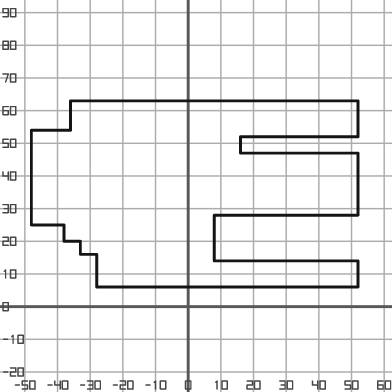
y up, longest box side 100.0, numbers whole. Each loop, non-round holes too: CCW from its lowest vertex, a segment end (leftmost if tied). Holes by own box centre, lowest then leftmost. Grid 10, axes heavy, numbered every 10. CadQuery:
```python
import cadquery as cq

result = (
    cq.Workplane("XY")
    .moveTo(-28.0, 6.0)
    .lineTo(52.0, 6.0)
    .lineTo(52.0, 14.0)
    .lineTo(8.0, 14.0)
    .lineTo(8.0, 28.0)
    .lineTo(52.0, 28.0)
    .lineTo(52.0, 47.0)
    .lineTo(16.0, 47.0)
    .lineTo(16.0, 52.0)
    .lineTo(52.0, 52.0)
    .lineTo(52.0, 63.0)
    .lineTo(-36.0, 63.0)
    .lineTo(-36.0, 54.0)
    .lineTo(-48.0, 54.0)
    .lineTo(-48.0, 25.0)
    .lineTo(-38.0, 25.0)
    .lineTo(-38.0, 20.0)
    .lineTo(-33.0, 20.0)
    .lineTo(-33.0, 16.0)
    .lineTo(-28.0, 16.0)
    .close()
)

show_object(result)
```